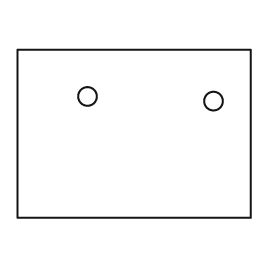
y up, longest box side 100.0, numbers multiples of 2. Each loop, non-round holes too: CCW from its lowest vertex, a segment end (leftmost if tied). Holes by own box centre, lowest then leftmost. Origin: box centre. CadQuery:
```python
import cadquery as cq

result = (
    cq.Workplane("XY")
    .moveTo(-50.0, -36.0)
    .lineTo(50.0, -36.0)
    .lineTo(50.0, 36.0)
    .lineTo(-50.0, 36.0)
    .close()
    .moveTo(34.0, 14.0)
    .circle(4.0)
    .moveTo(-20.0, 16.0)
    .circle(4.0)
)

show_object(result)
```